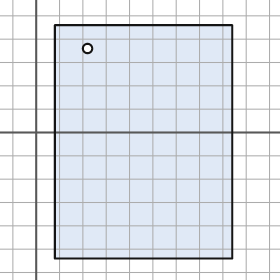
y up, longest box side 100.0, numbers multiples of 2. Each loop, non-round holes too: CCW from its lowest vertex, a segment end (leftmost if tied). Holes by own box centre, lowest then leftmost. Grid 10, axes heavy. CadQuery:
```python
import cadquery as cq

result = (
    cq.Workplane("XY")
    .moveTo(8.0, -54.0)
    .lineTo(84.0, -54.0)
    .lineTo(84.0, 46.0)
    .lineTo(8.0, 46.0)
    .close()
    .moveTo(22.0, 36.0)
    .circle(2.0)
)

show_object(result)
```